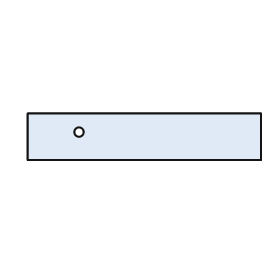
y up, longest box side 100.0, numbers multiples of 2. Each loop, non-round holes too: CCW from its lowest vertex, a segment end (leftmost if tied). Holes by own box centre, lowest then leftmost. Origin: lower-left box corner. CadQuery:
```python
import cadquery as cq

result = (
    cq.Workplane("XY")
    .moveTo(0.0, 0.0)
    .lineTo(100.0, 0.0)
    .lineTo(100.0, 20.0)
    .lineTo(0.0, 20.0)
    .close()
    .moveTo(22.0, 12.0)
    .circle(2.0)
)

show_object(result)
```